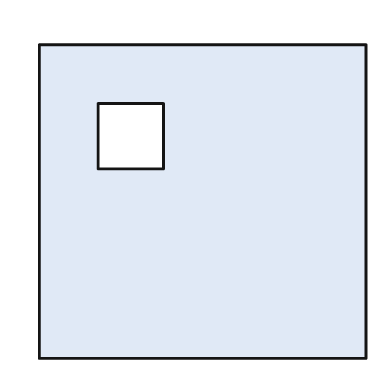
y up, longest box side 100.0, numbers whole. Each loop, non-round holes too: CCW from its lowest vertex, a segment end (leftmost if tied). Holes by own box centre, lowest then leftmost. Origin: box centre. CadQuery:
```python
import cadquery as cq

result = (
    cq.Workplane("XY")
    .moveTo(-50.0, -48.0)
    .lineTo(50.0, -48.0)
    .lineTo(50.0, 48.0)
    .lineTo(-50.0, 48.0)
    .close()
    .moveTo(-32.0, 10.0)
    .lineTo(-12.0, 10.0)
    .lineTo(-12.0, 30.0)
    .lineTo(-32.0, 30.0)
    .close()
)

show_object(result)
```